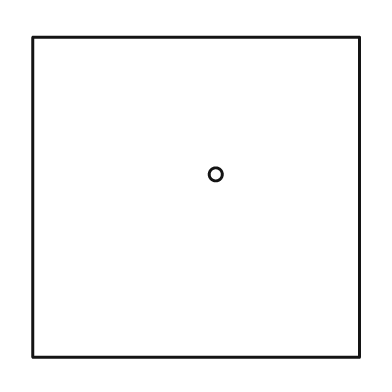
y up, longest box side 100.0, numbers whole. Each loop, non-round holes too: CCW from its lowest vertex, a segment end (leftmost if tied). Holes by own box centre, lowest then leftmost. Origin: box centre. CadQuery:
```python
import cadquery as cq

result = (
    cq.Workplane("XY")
    .moveTo(-50.0, -49.0)
    .lineTo(50.0, -49.0)
    .lineTo(50.0, 49.0)
    .lineTo(-50.0, 49.0)
    .close()
    .moveTo(6.0, 7.0)
    .circle(2.0)
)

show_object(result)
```